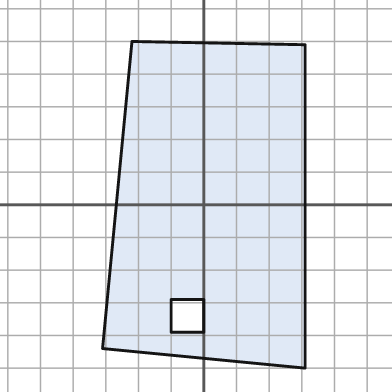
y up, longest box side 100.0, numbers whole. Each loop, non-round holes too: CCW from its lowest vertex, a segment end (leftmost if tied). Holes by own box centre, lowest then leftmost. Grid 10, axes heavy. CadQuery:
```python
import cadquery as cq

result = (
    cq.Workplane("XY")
    .moveTo(31.0, -50.0)
    .lineTo(31.0, 49.0)
    .lineTo(-22.0, 50.0)
    .lineTo(-31.0, -44.0)
    .close()
    .moveTo(-10.0, -39.0)
    .lineTo(0.0, -39.0)
    .lineTo(0.0, -29.0)
    .lineTo(-10.0, -29.0)
    .close()
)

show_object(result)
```